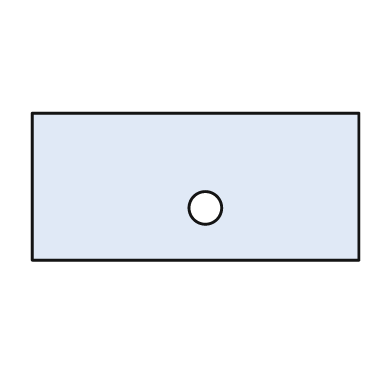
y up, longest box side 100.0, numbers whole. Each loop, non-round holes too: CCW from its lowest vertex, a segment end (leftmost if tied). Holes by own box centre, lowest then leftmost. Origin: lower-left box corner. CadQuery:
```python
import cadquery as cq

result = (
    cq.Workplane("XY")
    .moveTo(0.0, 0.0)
    .lineTo(100.0, 0.0)
    .lineTo(100.0, 45.0)
    .lineTo(0.0, 45.0)
    .close()
    .moveTo(53.0, 16.0)
    .circle(5.0)
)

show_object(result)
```